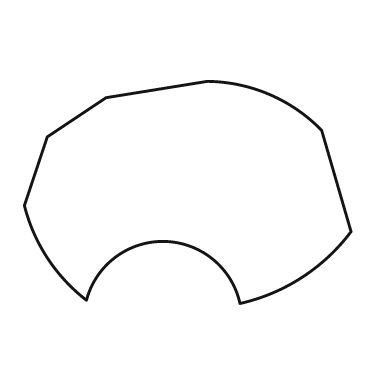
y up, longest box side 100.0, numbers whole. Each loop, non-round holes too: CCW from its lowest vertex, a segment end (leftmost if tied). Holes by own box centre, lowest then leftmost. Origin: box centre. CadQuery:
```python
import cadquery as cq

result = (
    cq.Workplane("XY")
    .moveTo(16.0, -34.0)
    .threePointArc((35.0, -26.0), (50.0, -12.0))
    .lineTo(41.0, 19.0)
    .threePointArc((25.0, 30.0), (6.0, 34.0))
    .lineTo(-25.0, 29.0)
    .lineTo(-43.0, 17.0)
    .lineTo(-50.0, -4.0)
    .threePointArc((-43.0, -20.0), (-31.0, -33.0))
    .threePointArc((-7.0, -15.0), (16.0, -34.0))
    .close()
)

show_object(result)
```